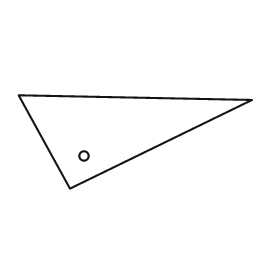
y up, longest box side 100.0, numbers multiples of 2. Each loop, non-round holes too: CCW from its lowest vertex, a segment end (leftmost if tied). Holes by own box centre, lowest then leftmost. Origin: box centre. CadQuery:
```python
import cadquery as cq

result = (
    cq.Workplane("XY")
    .moveTo(-28.0, -20.0)
    .lineTo(50.0, 18.0)
    .lineTo(-50.0, 20.0)
    .close()
    .moveTo(-22.0, -6.0)
    .circle(2.0)
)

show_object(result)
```